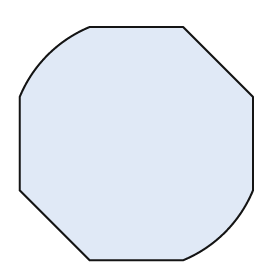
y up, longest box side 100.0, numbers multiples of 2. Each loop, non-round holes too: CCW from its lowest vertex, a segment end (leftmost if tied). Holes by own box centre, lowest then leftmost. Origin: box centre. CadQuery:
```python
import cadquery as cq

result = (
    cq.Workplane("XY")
    .moveTo(-20.0, -50.0)
    .lineTo(20.0, -50.0)
    .threePointArc((38.0, -38.0), (50.0, -20.0))
    .lineTo(50.0, 20.0)
    .lineTo(20.0, 50.0)
    .lineTo(-20.0, 50.0)
    .threePointArc((-38.0, 38.0), (-50.0, 20.0))
    .lineTo(-50.0, -20.0)
    .close()
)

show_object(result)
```